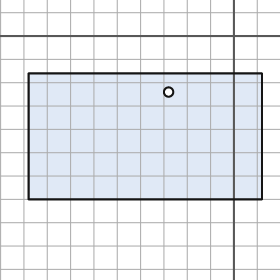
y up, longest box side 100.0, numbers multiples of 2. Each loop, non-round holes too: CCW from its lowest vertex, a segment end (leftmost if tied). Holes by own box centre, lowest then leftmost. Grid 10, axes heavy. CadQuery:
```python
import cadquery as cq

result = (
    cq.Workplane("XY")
    .moveTo(-88.0, -70.0)
    .lineTo(12.0, -70.0)
    .lineTo(12.0, -16.0)
    .lineTo(-88.0, -16.0)
    .close()
    .moveTo(-28.0, -24.0)
    .circle(2.0)
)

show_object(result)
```